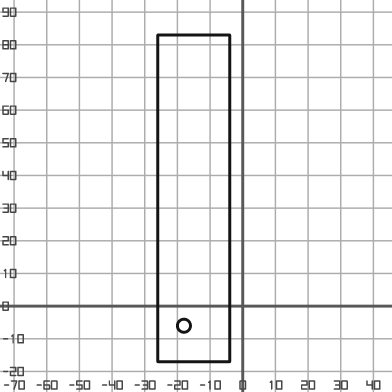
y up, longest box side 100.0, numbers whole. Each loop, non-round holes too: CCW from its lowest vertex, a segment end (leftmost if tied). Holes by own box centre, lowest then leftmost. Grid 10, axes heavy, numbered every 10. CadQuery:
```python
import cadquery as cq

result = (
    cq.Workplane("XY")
    .moveTo(-26.0, -17.0)
    .lineTo(-4.0, -17.0)
    .lineTo(-4.0, 83.0)
    .lineTo(-26.0, 83.0)
    .close()
    .moveTo(-18.0, -6.0)
    .circle(2.0)
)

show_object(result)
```